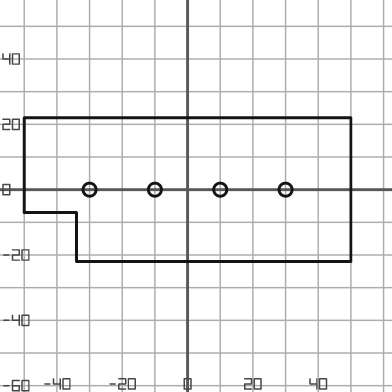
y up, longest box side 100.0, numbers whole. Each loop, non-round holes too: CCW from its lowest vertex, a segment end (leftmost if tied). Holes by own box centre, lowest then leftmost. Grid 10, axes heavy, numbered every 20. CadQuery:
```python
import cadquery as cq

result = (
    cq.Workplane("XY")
    .moveTo(-34.0, -22.0)
    .lineTo(50.0, -22.0)
    .lineTo(50.0, 22.0)
    .lineTo(-50.0, 22.0)
    .lineTo(-50.0, -7.0)
    .lineTo(-34.0, -7.0)
    .close()
    .moveTo(-30.0, 0.0)
    .circle(2.0)
    .moveTo(-10.0, 0.0)
    .circle(2.0)
    .moveTo(10.0, 0.0)
    .circle(2.0)
    .moveTo(30.0, 0.0)
    .circle(2.0)
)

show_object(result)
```